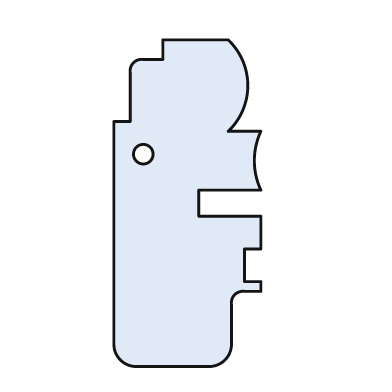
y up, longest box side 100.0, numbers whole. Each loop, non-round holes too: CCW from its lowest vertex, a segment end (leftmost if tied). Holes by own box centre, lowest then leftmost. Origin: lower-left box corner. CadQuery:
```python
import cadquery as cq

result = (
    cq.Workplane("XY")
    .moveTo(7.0, 0.0)
    .lineTo(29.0, 0.0)
    .threePointArc((34.0, 2.0), (36.0, 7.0))
    .lineTo(36.0, 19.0)
    .threePointArc((37.0, 22.0), (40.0, 23.0))
    .lineTo(45.0, 23.0)
    .lineTo(45.0, 26.0)
    .lineTo(40.0, 26.0)
    .lineTo(40.0, 36.0)
    .lineTo(45.0, 36.0)
    .lineTo(45.0, 46.0)
    .lineTo(26.0, 46.0)
    .lineTo(26.0, 54.0)
    .lineTo(45.0, 54.0)
    .threePointArc((43.0, 63.0), (45.0, 72.0))
    .lineTo(35.0, 72.0)
    .threePointArc((41.0, 86.0), (35.0, 100.0))
    .lineTo(15.0, 100.0)
    .lineTo(15.0, 94.0)
    .lineTo(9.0, 94.0)
    .threePointArc((6.0, 93.0), (5.0, 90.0))
    .lineTo(5.0, 75.0)
    .lineTo(0.0, 75.0)
    .lineTo(0.0, 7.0)
    .threePointArc((2.0, 2.0), (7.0, 0.0))
    .close()
    .moveTo(9.0, 65.0)
    .circle(3.0)
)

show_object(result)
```